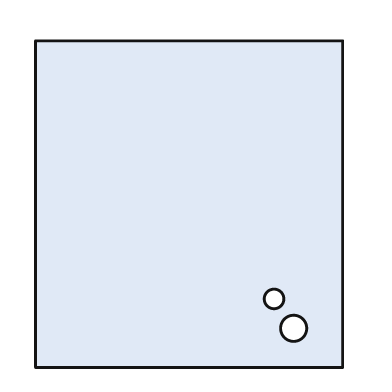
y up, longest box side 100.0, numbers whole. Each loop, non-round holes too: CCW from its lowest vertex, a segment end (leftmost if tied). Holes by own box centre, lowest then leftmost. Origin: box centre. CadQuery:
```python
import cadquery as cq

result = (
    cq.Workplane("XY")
    .moveTo(-47.0, -50.0)
    .lineTo(47.0, -50.0)
    .lineTo(47.0, 50.0)
    .lineTo(-47.0, 50.0)
    .close()
    .moveTo(32.0, -38.0)
    .circle(4.0)
    .moveTo(26.0, -29.0)
    .circle(3.0)
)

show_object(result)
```